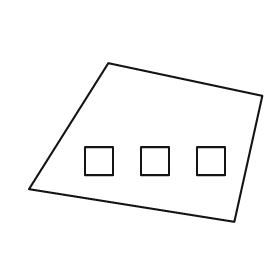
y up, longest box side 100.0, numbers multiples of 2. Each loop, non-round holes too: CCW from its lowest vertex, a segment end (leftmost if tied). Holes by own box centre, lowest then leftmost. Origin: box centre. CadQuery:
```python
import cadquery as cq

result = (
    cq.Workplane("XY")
    .moveTo(38.0, -34.0)
    .lineTo(50.0, 20.0)
    .lineTo(-16.0, 34.0)
    .lineTo(-50.0, -20.0)
    .close()
    .moveTo(-26.0, -14.0)
    .lineTo(-14.0, -14.0)
    .lineTo(-14.0, -2.0)
    .lineTo(-26.0, -2.0)
    .close()
    .moveTo(-2.0, -14.0)
    .lineTo(10.0, -14.0)
    .lineTo(10.0, -2.0)
    .lineTo(-2.0, -2.0)
    .close()
    .moveTo(22.0, -14.0)
    .lineTo(34.0, -14.0)
    .lineTo(34.0, -2.0)
    .lineTo(22.0, -2.0)
    .close()
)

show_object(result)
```